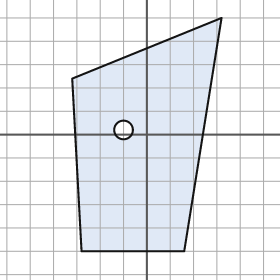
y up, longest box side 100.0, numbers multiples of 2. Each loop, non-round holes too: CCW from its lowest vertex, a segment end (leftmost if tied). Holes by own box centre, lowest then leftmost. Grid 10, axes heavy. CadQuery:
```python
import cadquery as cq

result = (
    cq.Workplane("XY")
    .moveTo(-28.0, -50.0)
    .lineTo(16.0, -50.0)
    .lineTo(32.0, 50.0)
    .lineTo(-32.0, 24.0)
    .close()
    .moveTo(-10.0, 2.0)
    .circle(4.0)
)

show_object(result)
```